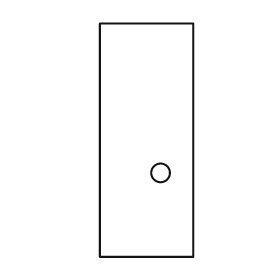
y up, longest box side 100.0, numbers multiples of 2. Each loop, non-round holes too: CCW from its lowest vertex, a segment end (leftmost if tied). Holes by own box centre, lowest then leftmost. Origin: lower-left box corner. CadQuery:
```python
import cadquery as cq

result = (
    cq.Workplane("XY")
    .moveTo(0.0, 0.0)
    .lineTo(40.0, 0.0)
    .lineTo(40.0, 100.0)
    .lineTo(0.0, 100.0)
    .close()
    .moveTo(26.0, 36.0)
    .circle(4.0)
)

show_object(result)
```